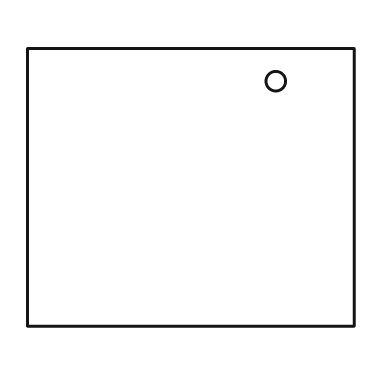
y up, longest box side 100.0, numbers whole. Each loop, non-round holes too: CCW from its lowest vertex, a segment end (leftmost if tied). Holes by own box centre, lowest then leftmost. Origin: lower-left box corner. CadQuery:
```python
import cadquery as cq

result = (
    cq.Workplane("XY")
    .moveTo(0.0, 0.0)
    .lineTo(100.0, 0.0)
    .lineTo(100.0, 85.0)
    .lineTo(0.0, 85.0)
    .close()
    .moveTo(76.0, 75.0)
    .circle(3.0)
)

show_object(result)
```